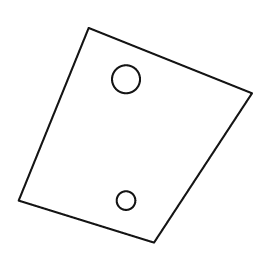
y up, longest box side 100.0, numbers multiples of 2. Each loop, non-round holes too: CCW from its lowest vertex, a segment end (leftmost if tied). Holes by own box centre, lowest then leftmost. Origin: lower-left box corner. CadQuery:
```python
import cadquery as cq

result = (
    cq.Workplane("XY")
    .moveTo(58.0, 0.0)
    .lineTo(100.0, 64.0)
    .lineTo(30.0, 92.0)
    .lineTo(0.0, 18.0)
    .close()
    .moveTo(46.0, 18.0)
    .circle(4.0)
    .moveTo(46.0, 70.0)
    .circle(6.0)
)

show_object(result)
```